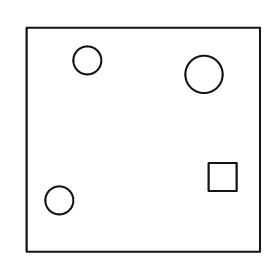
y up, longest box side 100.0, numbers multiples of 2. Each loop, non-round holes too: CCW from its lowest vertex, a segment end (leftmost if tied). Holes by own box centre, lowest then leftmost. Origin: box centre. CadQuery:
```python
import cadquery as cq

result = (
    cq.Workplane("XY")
    .moveTo(-50.0, -48.0)
    .lineTo(50.0, -48.0)
    .lineTo(50.0, 48.0)
    .lineTo(-50.0, 48.0)
    .close()
    .moveTo(-36.0, -26.0)
    .circle(6.0)
    .moveTo(28.0, -22.0)
    .lineTo(40.0, -22.0)
    .lineTo(40.0, -10.0)
    .lineTo(28.0, -10.0)
    .close()
    .moveTo(26.0, 28.0)
    .circle(8.0)
    .moveTo(-24.0, 34.0)
    .circle(6.0)
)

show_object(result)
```